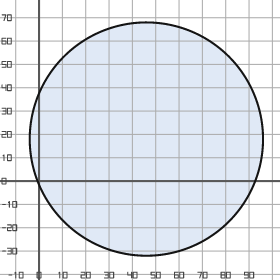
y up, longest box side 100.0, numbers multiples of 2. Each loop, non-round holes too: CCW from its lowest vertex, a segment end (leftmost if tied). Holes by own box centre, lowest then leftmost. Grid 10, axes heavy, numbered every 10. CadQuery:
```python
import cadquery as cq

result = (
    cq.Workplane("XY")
    .moveTo(46.0, 18.0)
    .circle(50.0)
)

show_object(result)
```